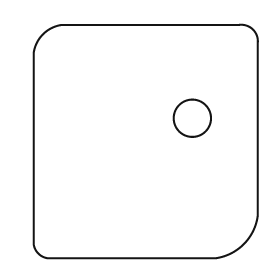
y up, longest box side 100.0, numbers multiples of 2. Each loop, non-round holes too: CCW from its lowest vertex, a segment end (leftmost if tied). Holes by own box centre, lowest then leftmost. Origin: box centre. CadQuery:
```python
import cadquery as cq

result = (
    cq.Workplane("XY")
    .moveTo(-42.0, -50.0)
    .lineTo(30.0, -50.0)
    .threePointArc((42.0, -44.0), (48.0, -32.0))
    .lineTo(48.0, 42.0)
    .threePointArc((46.0, 48.0), (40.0, 50.0))
    .lineTo(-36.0, 50.0)
    .threePointArc((-44.0, 46.0), (-48.0, 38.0))
    .lineTo(-48.0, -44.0)
    .threePointArc((-46.0, -48.0), (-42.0, -50.0))
    .close()
    .moveTo(20.0, 10.0)
    .circle(8.0)
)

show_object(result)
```